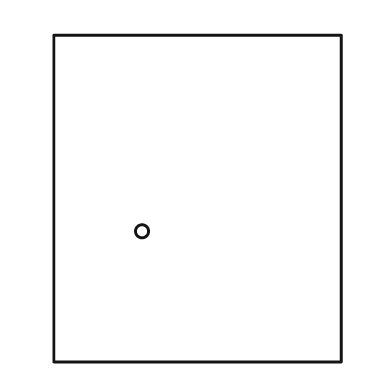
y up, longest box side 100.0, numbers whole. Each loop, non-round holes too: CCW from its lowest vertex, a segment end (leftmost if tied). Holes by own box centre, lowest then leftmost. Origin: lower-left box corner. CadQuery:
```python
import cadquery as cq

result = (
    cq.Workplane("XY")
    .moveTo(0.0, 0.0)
    .lineTo(88.0, 0.0)
    .lineTo(88.0, 100.0)
    .lineTo(0.0, 100.0)
    .close()
    .moveTo(27.0, 40.0)
    .circle(2.0)
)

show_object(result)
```